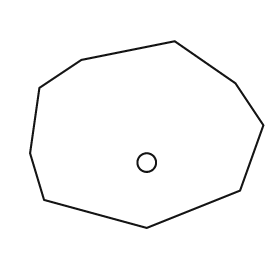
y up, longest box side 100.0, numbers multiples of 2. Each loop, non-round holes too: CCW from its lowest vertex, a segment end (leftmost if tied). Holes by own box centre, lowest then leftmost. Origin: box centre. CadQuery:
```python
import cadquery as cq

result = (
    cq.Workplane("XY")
    .moveTo(0.0, -40.0)
    .lineTo(40.0, -24.0)
    .lineTo(50.0, 4.0)
    .lineTo(38.0, 22.0)
    .lineTo(12.0, 40.0)
    .lineTo(-28.0, 32.0)
    .lineTo(-46.0, 20.0)
    .lineTo(-50.0, -8.0)
    .lineTo(-44.0, -28.0)
    .close()
    .moveTo(0.0, -12.0)
    .circle(4.0)
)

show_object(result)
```